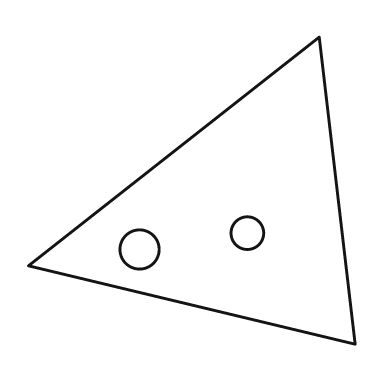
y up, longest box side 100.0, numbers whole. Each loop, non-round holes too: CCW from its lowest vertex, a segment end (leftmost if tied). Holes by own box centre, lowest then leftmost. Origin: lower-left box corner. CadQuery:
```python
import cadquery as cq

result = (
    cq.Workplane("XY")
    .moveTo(100.0, 0.0)
    .lineTo(89.0, 94.0)
    .lineTo(0.0, 24.0)
    .close()
    .moveTo(34.0, 29.0)
    .circle(6.0)
    .moveTo(67.0, 34.0)
    .circle(5.0)
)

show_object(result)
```